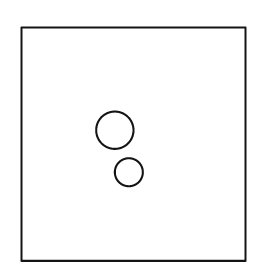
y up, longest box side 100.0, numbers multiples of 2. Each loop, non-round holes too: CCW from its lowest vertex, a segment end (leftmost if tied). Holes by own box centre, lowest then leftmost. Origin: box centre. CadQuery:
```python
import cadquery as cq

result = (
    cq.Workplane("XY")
    .moveTo(-48.0, -50.0)
    .lineTo(48.0, -50.0)
    .lineTo(48.0, 50.0)
    .lineTo(-48.0, 50.0)
    .close()
    .moveTo(-2.0, -12.0)
    .circle(6.0)
    .moveTo(-8.0, 6.0)
    .circle(8.0)
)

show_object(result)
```